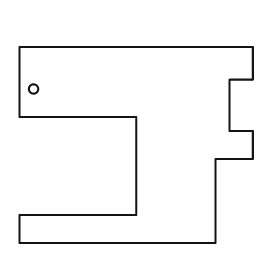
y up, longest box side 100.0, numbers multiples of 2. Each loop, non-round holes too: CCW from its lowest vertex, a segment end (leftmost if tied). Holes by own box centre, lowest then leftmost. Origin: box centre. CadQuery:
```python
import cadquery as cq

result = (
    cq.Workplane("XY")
    .moveTo(-50.0, -42.0)
    .lineTo(34.0, -42.0)
    .lineTo(34.0, -6.0)
    .lineTo(50.0, -6.0)
    .lineTo(50.0, 6.0)
    .lineTo(40.0, 6.0)
    .lineTo(40.0, 28.0)
    .lineTo(50.0, 28.0)
    .lineTo(50.0, 42.0)
    .lineTo(-50.0, 42.0)
    .lineTo(-50.0, 12.0)
    .lineTo(0.0, 12.0)
    .lineTo(0.0, -30.0)
    .lineTo(-50.0, -30.0)
    .close()
    .moveTo(-44.0, 24.0)
    .circle(2.0)
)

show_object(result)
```